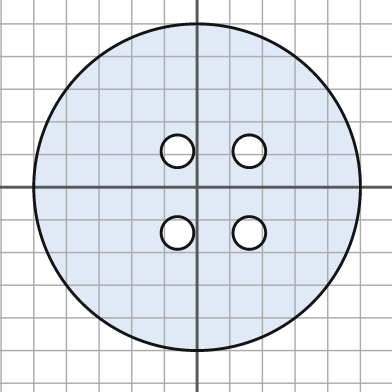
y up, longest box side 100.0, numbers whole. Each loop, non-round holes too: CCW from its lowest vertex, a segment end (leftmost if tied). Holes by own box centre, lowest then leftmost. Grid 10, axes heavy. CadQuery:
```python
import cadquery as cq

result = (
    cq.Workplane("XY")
    .moveTo(0.0, 0.0)
    .circle(50.0)
    .moveTo(-6.0, -14.0)
    .circle(5.0)
    .moveTo(16.0, -14.0)
    .circle(5.0)
    .moveTo(-6.0, 11.0)
    .circle(5.0)
    .moveTo(16.0, 11.0)
    .circle(5.0)
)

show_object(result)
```